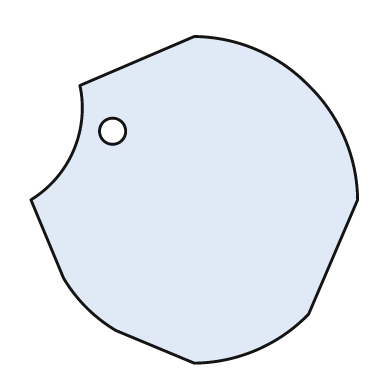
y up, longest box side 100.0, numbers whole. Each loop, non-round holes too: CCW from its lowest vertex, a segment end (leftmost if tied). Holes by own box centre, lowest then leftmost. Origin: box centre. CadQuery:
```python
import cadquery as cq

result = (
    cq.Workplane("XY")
    .moveTo(0.0, -50.0)
    .threePointArc((19.0, -46.0), (35.0, -35.0))
    .lineTo(50.0, 0.0)
    .threePointArc((46.0, 19.0), (35.0, 35.0))
    .threePointArc((19.0, 46.0), (0.0, 50.0))
    .lineTo(-35.0, 35.0)
    .threePointArc((-37.0, 15.0), (-50.0, 0.0))
    .lineTo(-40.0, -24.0)
    .threePointArc((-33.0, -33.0), (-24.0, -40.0))
    .close()
    .moveTo(-25.0, 21.0)
    .circle(4.0)
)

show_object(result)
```